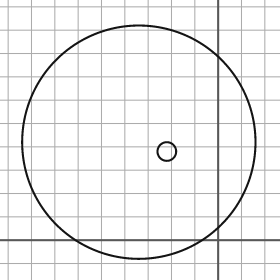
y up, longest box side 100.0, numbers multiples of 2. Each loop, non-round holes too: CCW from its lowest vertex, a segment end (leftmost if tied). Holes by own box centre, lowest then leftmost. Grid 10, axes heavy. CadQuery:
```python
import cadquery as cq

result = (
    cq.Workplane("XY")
    .moveTo(-34.0, 42.0)
    .circle(50.0)
    .moveTo(-22.0, 38.0)
    .circle(4.0)
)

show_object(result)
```